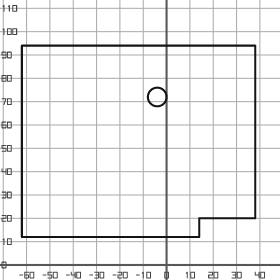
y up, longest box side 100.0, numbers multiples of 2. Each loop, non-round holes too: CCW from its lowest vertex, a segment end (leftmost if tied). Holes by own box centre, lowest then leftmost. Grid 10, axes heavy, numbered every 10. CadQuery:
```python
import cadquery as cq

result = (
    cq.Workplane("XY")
    .moveTo(-62.0, 12.0)
    .lineTo(14.0, 12.0)
    .lineTo(14.0, 20.0)
    .lineTo(38.0, 20.0)
    .lineTo(38.0, 94.0)
    .lineTo(-62.0, 94.0)
    .close()
    .moveTo(-4.0, 72.0)
    .circle(4.0)
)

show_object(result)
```